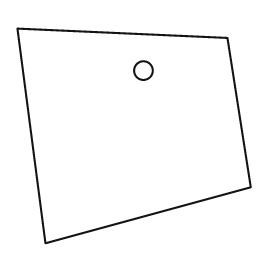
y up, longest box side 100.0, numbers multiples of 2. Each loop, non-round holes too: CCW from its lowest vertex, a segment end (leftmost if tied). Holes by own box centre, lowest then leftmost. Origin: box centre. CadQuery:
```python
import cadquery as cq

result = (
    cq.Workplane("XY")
    .moveTo(-38.0, -46.0)
    .lineTo(50.0, -22.0)
    .lineTo(40.0, 42.0)
    .lineTo(-50.0, 46.0)
    .close()
    .moveTo(4.0, 28.0)
    .circle(4.0)
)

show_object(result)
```